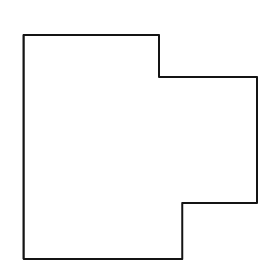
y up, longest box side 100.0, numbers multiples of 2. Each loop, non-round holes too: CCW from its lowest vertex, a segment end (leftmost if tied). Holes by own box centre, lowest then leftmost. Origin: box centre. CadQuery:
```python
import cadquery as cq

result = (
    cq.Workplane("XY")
    .moveTo(-50.0, -48.0)
    .lineTo(18.0, -48.0)
    .lineTo(18.0, -24.0)
    .lineTo(50.0, -24.0)
    .lineTo(50.0, 30.0)
    .lineTo(8.0, 30.0)
    .lineTo(8.0, 48.0)
    .lineTo(-50.0, 48.0)
    .close()
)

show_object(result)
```